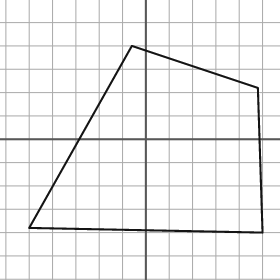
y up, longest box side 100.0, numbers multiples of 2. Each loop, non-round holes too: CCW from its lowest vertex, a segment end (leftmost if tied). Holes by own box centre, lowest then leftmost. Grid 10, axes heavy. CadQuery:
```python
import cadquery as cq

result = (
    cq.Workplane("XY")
    .moveTo(50.0, -40.0)
    .lineTo(48.0, 22.0)
    .lineTo(-6.0, 40.0)
    .lineTo(-50.0, -38.0)
    .close()
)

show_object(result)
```